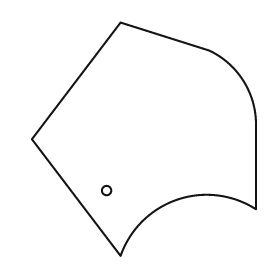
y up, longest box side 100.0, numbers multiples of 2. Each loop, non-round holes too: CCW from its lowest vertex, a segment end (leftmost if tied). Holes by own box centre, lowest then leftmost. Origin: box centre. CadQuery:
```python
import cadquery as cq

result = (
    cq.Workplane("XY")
    .moveTo(-10.0, -50.0)
    .threePointArc((14.0, -26.0), (48.0, -30.0))
    .lineTo(48.0, 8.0)
    .threePointArc((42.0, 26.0), (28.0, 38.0))
    .lineTo(-10.0, 50.0)
    .lineTo(-48.0, 0.0)
    .close()
    .moveTo(-16.0, -22.0)
    .circle(2.0)
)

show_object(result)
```